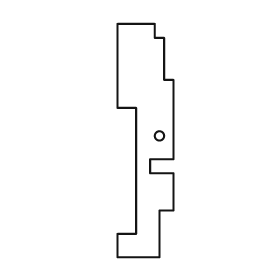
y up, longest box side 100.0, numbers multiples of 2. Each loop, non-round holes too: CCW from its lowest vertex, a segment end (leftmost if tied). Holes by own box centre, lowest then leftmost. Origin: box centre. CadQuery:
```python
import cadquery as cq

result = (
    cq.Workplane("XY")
    .moveTo(-12.0, -50.0)
    .lineTo(6.0, -50.0)
    .lineTo(6.0, -30.0)
    .lineTo(12.0, -30.0)
    .lineTo(12.0, -14.0)
    .lineTo(2.0, -14.0)
    .lineTo(2.0, -8.0)
    .lineTo(12.0, -8.0)
    .lineTo(12.0, 26.0)
    .lineTo(8.0, 26.0)
    .lineTo(8.0, 44.0)
    .lineTo(4.0, 44.0)
    .lineTo(4.0, 50.0)
    .lineTo(-12.0, 50.0)
    .lineTo(-12.0, 14.0)
    .lineTo(-4.0, 14.0)
    .lineTo(-4.0, -40.0)
    .lineTo(-12.0, -40.0)
    .close()
    .moveTo(6.0, 2.0)
    .circle(2.0)
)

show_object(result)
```